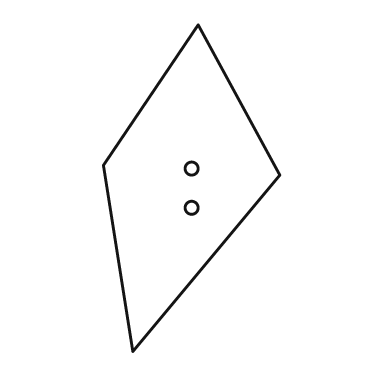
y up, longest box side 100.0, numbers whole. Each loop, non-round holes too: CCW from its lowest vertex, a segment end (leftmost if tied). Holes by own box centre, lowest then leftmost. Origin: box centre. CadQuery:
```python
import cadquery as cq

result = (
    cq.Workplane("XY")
    .moveTo(-18.0, -50.0)
    .lineTo(27.0, 4.0)
    .lineTo(2.0, 50.0)
    .lineTo(-27.0, 7.0)
    .close()
    .moveTo(0.0, -6.0)
    .circle(2.0)
    .moveTo(0.0, 6.0)
    .circle(2.0)
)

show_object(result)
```